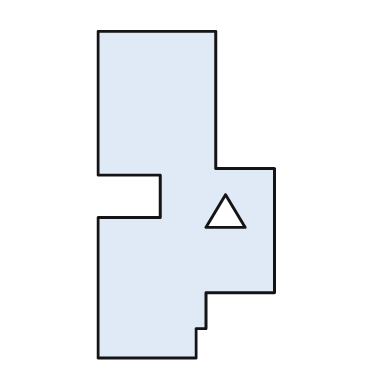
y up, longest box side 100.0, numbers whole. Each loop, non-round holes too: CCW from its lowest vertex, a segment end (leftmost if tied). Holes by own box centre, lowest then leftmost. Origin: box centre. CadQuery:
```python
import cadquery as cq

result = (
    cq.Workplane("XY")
    .moveTo(-27.0, -50.0)
    .lineTo(3.0, -50.0)
    .lineTo(3.0, -41.0)
    .lineTo(6.0, -41.0)
    .lineTo(6.0, -30.0)
    .lineTo(27.0, -30.0)
    .lineTo(27.0, 8.0)
    .lineTo(9.0, 8.0)
    .lineTo(9.0, 50.0)
    .lineTo(-27.0, 50.0)
    .lineTo(-27.0, 6.0)
    .lineTo(-8.0, 6.0)
    .lineTo(-8.0, -7.0)
    .lineTo(-27.0, -7.0)
    .close()
    .moveTo(6.0, -10.0)
    .lineTo(18.0, -10.0)
    .lineTo(12.0, 0.0)
    .close()
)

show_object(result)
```